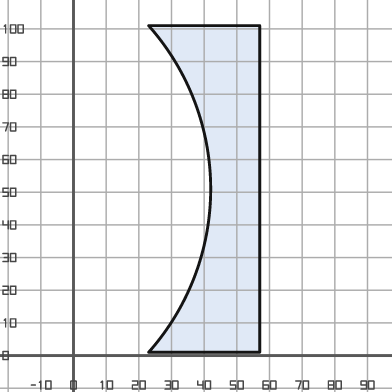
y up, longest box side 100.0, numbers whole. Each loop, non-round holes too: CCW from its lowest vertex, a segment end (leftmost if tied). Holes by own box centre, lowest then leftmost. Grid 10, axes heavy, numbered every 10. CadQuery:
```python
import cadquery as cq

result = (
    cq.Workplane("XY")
    .moveTo(23.0, 1.0)
    .lineTo(57.0, 1.0)
    .lineTo(57.0, 101.0)
    .lineTo(23.0, 101.0)
    .threePointArc((42.0, 51.0), (23.0, 1.0))
    .close()
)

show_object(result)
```